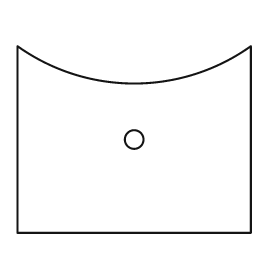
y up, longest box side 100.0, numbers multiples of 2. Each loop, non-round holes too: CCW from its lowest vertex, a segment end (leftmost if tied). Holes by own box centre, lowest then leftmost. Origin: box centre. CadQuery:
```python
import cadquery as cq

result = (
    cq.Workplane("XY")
    .moveTo(-50.0, -40.0)
    .lineTo(50.0, -40.0)
    .lineTo(50.0, 40.0)
    .threePointArc((0.0, 24.0), (-50.0, 40.0))
    .close()
    .moveTo(0.0, 0.0)
    .circle(4.0)
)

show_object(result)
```